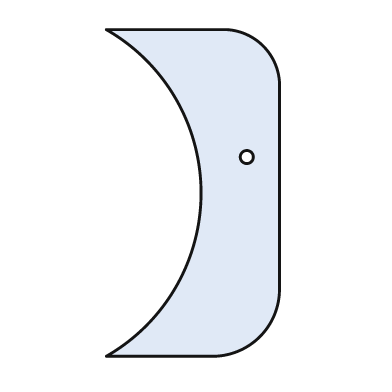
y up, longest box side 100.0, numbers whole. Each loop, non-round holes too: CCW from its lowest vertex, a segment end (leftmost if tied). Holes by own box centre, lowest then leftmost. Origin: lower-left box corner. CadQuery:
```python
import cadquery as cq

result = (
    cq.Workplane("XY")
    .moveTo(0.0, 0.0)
    .lineTo(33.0, 0.0)
    .threePointArc((47.0, 6.0), (53.0, 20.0))
    .lineTo(53.0, 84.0)
    .threePointArc((48.0, 95.0), (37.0, 100.0))
    .lineTo(0.0, 100.0)
    .threePointArc((29.0, 50.0), (0.0, 0.0))
    .close()
    .moveTo(43.0, 61.0)
    .circle(2.0)
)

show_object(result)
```